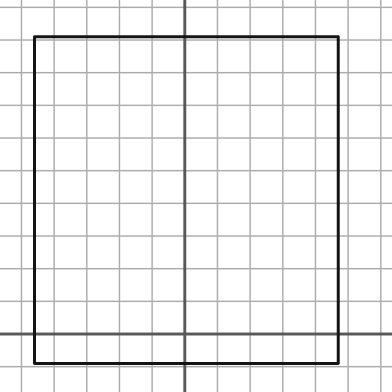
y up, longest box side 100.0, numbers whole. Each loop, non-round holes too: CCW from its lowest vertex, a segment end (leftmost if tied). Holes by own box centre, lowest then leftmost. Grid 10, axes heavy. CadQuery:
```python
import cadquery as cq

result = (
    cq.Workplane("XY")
    .moveTo(-46.0, -9.0)
    .lineTo(47.0, -9.0)
    .lineTo(47.0, 91.0)
    .lineTo(-46.0, 91.0)
    .close()
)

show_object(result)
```